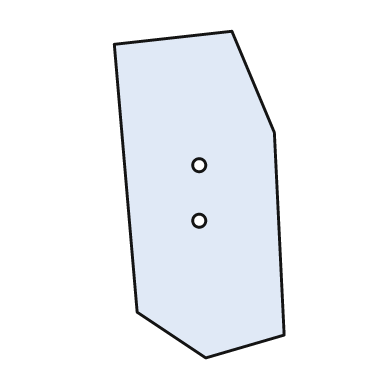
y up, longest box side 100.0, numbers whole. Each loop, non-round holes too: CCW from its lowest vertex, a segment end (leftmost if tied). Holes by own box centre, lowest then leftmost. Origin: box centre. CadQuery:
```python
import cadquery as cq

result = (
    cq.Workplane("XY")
    .moveTo(2.0, -50.0)
    .lineTo(26.0, -43.0)
    .lineTo(23.0, 19.0)
    .lineTo(10.0, 50.0)
    .lineTo(-26.0, 46.0)
    .lineTo(-19.0, -36.0)
    .close()
    .moveTo(0.0, -8.0)
    .circle(2.0)
    .moveTo(0.0, 9.0)
    .circle(2.0)
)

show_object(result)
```